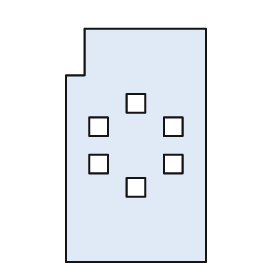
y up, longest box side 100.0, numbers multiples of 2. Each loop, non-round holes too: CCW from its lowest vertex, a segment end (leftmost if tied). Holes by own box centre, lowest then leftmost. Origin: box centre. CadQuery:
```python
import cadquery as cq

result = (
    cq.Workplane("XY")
    .moveTo(-30.0, -50.0)
    .lineTo(30.0, -50.0)
    .lineTo(30.0, 50.0)
    .lineTo(-22.0, 50.0)
    .lineTo(-22.0, 30.0)
    .lineTo(-30.0, 30.0)
    .close()
    .moveTo(-4.0, -22.0)
    .lineTo(4.0, -22.0)
    .lineTo(4.0, -14.0)
    .lineTo(-4.0, -14.0)
    .close()
    .moveTo(-20.0, -12.0)
    .lineTo(-12.0, -12.0)
    .lineTo(-12.0, -4.0)
    .lineTo(-20.0, -4.0)
    .close()
    .moveTo(12.0, -12.0)
    .lineTo(20.0, -12.0)
    .lineTo(20.0, -4.0)
    .lineTo(12.0, -4.0)
    .close()
    .moveTo(-20.0, 4.0)
    .lineTo(-12.0, 4.0)
    .lineTo(-12.0, 12.0)
    .lineTo(-20.0, 12.0)
    .close()
    .moveTo(12.0, 4.0)
    .lineTo(20.0, 4.0)
    .lineTo(20.0, 12.0)
    .lineTo(12.0, 12.0)
    .close()
    .moveTo(-4.0, 14.0)
    .lineTo(4.0, 14.0)
    .lineTo(4.0, 22.0)
    .lineTo(-4.0, 22.0)
    .close()
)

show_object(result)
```